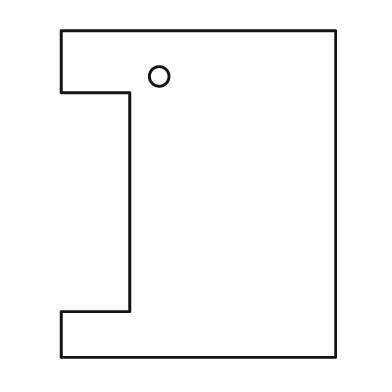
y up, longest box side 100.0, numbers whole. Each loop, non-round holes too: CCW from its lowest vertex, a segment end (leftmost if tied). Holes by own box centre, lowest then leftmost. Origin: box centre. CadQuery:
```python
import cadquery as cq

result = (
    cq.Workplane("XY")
    .moveTo(-42.0, -50.0)
    .lineTo(42.0, -50.0)
    .lineTo(42.0, 50.0)
    .lineTo(-42.0, 50.0)
    .lineTo(-42.0, 31.0)
    .lineTo(-21.0, 31.0)
    .lineTo(-21.0, -36.0)
    .lineTo(-42.0, -36.0)
    .close()
    .moveTo(-12.0, 36.0)
    .circle(3.0)
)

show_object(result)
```